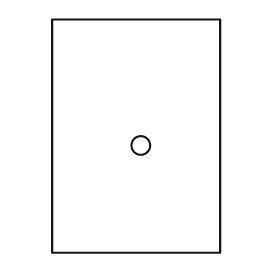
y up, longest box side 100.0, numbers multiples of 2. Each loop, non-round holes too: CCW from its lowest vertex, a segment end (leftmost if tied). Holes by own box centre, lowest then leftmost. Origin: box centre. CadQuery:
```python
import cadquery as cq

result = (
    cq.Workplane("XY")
    .moveTo(-36.0, -50.0)
    .lineTo(36.0, -50.0)
    .lineTo(36.0, 50.0)
    .lineTo(-36.0, 50.0)
    .close()
    .moveTo(2.0, -4.0)
    .circle(4.0)
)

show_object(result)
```